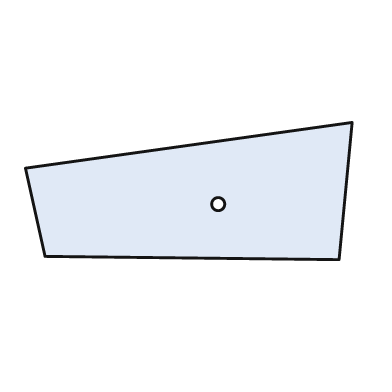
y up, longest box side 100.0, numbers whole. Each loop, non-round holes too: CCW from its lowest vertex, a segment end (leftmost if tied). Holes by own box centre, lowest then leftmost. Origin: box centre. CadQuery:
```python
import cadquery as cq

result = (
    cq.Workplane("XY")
    .moveTo(46.0, -21.0)
    .lineTo(50.0, 21.0)
    .lineTo(-50.0, 7.0)
    .lineTo(-44.0, -20.0)
    .close()
    .moveTo(9.0, -4.0)
    .circle(2.0)
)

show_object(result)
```